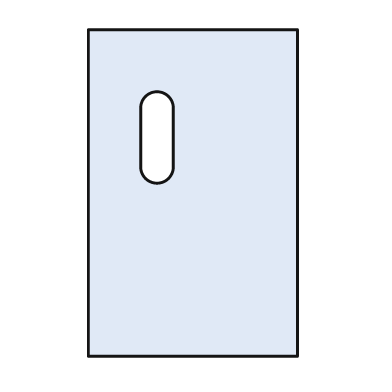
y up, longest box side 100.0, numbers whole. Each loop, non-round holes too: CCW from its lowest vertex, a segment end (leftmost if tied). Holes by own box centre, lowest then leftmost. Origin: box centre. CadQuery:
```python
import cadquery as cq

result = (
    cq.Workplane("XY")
    .moveTo(-32.0, -50.0)
    .lineTo(32.0, -50.0)
    .lineTo(32.0, 50.0)
    .lineTo(-32.0, 50.0)
    .close()
    .moveTo(-16.0, 8.0)
    .threePointArc((-11.0, 3.0), (-6.0, 8.0))
    .lineTo(-6.0, 26.0)
    .threePointArc((-11.0, 31.0), (-16.0, 26.0))
    .close()
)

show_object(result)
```